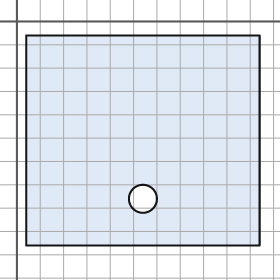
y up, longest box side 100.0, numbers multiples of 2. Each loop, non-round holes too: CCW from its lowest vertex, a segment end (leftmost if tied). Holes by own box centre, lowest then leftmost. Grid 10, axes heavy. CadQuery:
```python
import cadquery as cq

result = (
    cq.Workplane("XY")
    .moveTo(4.0, -96.0)
    .lineTo(104.0, -96.0)
    .lineTo(104.0, -6.0)
    .lineTo(4.0, -6.0)
    .close()
    .moveTo(54.0, -76.0)
    .circle(6.0)
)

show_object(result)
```